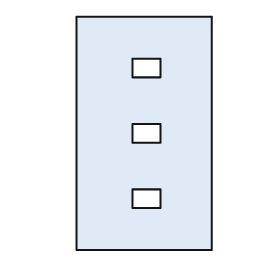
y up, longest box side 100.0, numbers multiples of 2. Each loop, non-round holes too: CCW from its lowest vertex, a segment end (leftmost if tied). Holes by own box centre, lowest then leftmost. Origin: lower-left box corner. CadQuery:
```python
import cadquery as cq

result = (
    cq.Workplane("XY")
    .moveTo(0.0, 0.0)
    .lineTo(58.0, 0.0)
    .lineTo(58.0, 100.0)
    .lineTo(0.0, 100.0)
    .close()
    .moveTo(24.0, 18.0)
    .lineTo(36.0, 18.0)
    .lineTo(36.0, 26.0)
    .lineTo(24.0, 26.0)
    .close()
    .moveTo(24.0, 46.0)
    .lineTo(36.0, 46.0)
    .lineTo(36.0, 54.0)
    .lineTo(24.0, 54.0)
    .close()
    .moveTo(24.0, 74.0)
    .lineTo(36.0, 74.0)
    .lineTo(36.0, 82.0)
    .lineTo(24.0, 82.0)
    .close()
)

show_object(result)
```